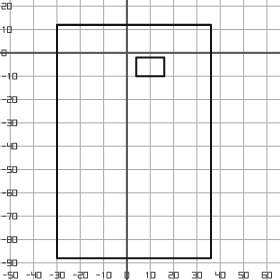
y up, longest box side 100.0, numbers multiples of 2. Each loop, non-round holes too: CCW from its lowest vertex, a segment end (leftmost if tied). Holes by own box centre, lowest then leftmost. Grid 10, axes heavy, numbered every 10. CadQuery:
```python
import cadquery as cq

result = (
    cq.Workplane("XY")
    .moveTo(-30.0, -88.0)
    .lineTo(36.0, -88.0)
    .lineTo(36.0, 12.0)
    .lineTo(-30.0, 12.0)
    .close()
    .moveTo(4.0, -10.0)
    .lineTo(16.0, -10.0)
    .lineTo(16.0, -2.0)
    .lineTo(4.0, -2.0)
    .close()
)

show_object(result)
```